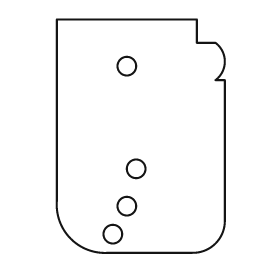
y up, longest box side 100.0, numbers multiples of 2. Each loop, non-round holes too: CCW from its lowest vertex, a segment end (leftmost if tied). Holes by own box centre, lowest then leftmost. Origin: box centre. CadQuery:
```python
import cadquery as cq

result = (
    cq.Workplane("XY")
    .moveTo(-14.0, -50.0)
    .lineTo(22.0, -50.0)
    .threePointArc((32.0, -46.0), (36.0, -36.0))
    .lineTo(36.0, 24.0)
    .lineTo(32.0, 24.0)
    .threePointArc((36.0, 32.0), (32.0, 40.0))
    .lineTo(24.0, 40.0)
    .lineTo(24.0, 50.0)
    .lineTo(-36.0, 50.0)
    .lineTo(-36.0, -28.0)
    .threePointArc((-30.0, -44.0), (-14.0, -50.0))
    .close()
    .moveTo(-12.0, -42.0)
    .circle(4.0)
    .moveTo(-6.0, -30.0)
    .circle(4.0)
    .moveTo(-2.0, -14.0)
    .circle(4.0)
    .moveTo(-6.0, 30.0)
    .circle(4.0)
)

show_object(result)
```